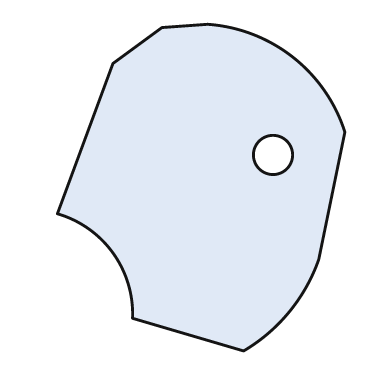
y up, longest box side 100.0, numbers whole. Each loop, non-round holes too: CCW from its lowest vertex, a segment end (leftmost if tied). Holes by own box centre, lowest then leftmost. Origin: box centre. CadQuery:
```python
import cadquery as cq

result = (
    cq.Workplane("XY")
    .moveTo(13.0, -50.0)
    .threePointArc((27.0, -38.0), (36.0, -22.0))
    .lineTo(44.0, 17.0)
    .threePointArc((28.0, 40.0), (2.0, 50.0))
    .lineTo(-12.0, 49.0)
    .lineTo(-27.0, 38.0)
    .lineTo(-44.0, -8.0)
    .threePointArc((-27.0, -20.0), (-21.0, -40.0))
    .close()
    .moveTo(22.0, 10.0)
    .circle(6.0)
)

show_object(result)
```